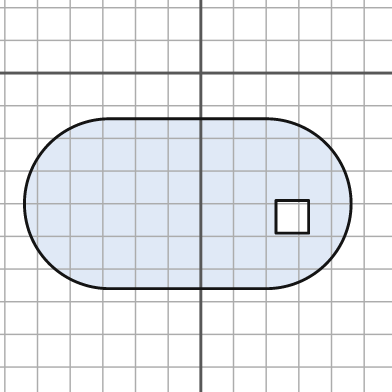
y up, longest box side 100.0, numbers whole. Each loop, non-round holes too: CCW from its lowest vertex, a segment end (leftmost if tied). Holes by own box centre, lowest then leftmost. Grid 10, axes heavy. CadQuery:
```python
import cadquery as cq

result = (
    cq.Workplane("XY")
    .moveTo(-28.0, -66.0)
    .lineTo(20.0, -66.0)
    .threePointArc((46.0, -40.0), (20.0, -14.0))
    .lineTo(-28.0, -14.0)
    .threePointArc((-54.0, -40.0), (-28.0, -66.0))
    .close()
    .moveTo(23.0, -49.0)
    .lineTo(33.0, -49.0)
    .lineTo(33.0, -39.0)
    .lineTo(23.0, -39.0)
    .close()
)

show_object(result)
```